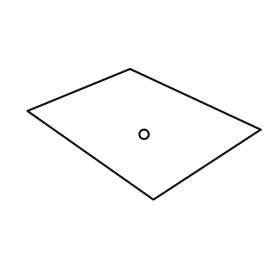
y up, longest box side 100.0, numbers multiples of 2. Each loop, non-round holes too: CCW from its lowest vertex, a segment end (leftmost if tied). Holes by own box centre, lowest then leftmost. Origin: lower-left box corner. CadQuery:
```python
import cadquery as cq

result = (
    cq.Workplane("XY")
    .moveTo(54.0, 0.0)
    .lineTo(100.0, 30.0)
    .lineTo(44.0, 56.0)
    .lineTo(0.0, 38.0)
    .close()
    .moveTo(50.0, 28.0)
    .circle(2.0)
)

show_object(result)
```